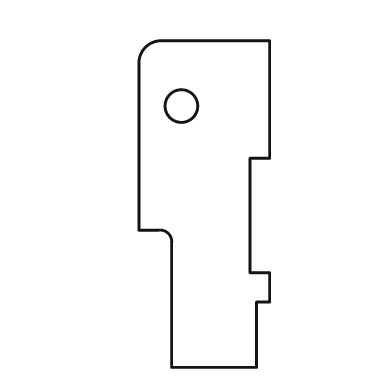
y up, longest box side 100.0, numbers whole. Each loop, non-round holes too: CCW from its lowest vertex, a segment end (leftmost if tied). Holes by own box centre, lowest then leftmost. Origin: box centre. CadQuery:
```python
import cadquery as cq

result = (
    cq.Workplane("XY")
    .moveTo(-10.0, -50.0)
    .lineTo(16.0, -50.0)
    .lineTo(16.0, -30.0)
    .lineTo(20.0, -30.0)
    .lineTo(20.0, -21.0)
    .lineTo(14.0, -21.0)
    .lineTo(14.0, 14.0)
    .lineTo(20.0, 14.0)
    .lineTo(20.0, 50.0)
    .lineTo(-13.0, 50.0)
    .threePointArc((-18.0, 48.0), (-20.0, 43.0))
    .lineTo(-20.0, -8.0)
    .lineTo(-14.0, -8.0)
    .threePointArc((-11.0, -9.0), (-10.0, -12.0))
    .close()
    .moveTo(-7.0, 30.0)
    .circle(5.0)
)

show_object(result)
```